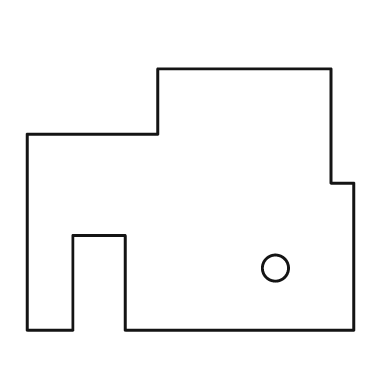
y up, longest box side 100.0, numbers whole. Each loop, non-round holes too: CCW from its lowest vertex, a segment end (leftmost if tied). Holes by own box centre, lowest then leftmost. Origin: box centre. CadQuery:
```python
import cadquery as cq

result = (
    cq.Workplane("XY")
    .moveTo(-50.0, -40.0)
    .lineTo(-36.0, -40.0)
    .lineTo(-36.0, -11.0)
    .lineTo(-20.0, -11.0)
    .lineTo(-20.0, -40.0)
    .lineTo(50.0, -40.0)
    .lineTo(50.0, 5.0)
    .lineTo(43.0, 5.0)
    .lineTo(43.0, 40.0)
    .lineTo(-10.0, 40.0)
    .lineTo(-10.0, 20.0)
    .lineTo(-50.0, 20.0)
    .close()
    .moveTo(26.0, -21.0)
    .circle(4.0)
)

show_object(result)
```